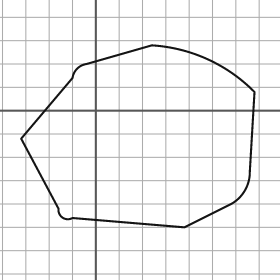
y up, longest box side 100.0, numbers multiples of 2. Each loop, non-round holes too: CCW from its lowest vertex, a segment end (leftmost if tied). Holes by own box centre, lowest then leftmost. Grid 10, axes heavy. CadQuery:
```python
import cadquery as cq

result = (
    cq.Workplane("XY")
    .moveTo(38.0, -50.0)
    .lineTo(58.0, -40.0)
    .threePointArc((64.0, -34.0), (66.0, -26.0))
    .lineTo(68.0, 8.0)
    .threePointArc((48.0, 22.0), (24.0, 28.0))
    .lineTo(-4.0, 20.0)
    .threePointArc((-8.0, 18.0), (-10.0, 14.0))
    .lineTo(-32.0, -12.0)
    .lineTo(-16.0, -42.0)
    .threePointArc((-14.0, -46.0), (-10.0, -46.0))
    .close()
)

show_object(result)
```